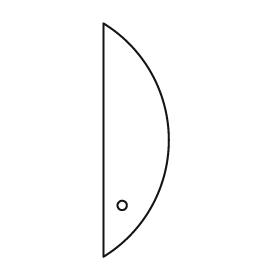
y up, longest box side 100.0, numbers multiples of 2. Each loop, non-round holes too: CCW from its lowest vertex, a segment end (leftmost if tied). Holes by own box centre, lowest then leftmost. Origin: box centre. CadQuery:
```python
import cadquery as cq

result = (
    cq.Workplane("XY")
    .moveTo(-14.0, -50.0)
    .threePointArc((14.0, 0.0), (-14.0, 50.0))
    .close()
    .moveTo(-6.0, -28.0)
    .circle(2.0)
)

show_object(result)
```